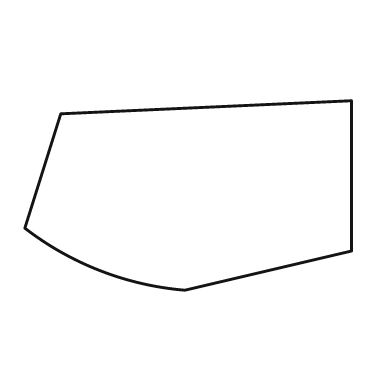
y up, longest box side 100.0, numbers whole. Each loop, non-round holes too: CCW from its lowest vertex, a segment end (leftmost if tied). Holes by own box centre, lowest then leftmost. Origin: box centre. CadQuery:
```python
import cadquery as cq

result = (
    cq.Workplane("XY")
    .moveTo(-1.0, -29.0)
    .lineTo(50.0, -17.0)
    .lineTo(50.0, 29.0)
    .lineTo(-39.0, 25.0)
    .lineTo(-50.0, -10.0)
    .threePointArc((-27.0, -23.0), (-1.0, -29.0))
    .close()
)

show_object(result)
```